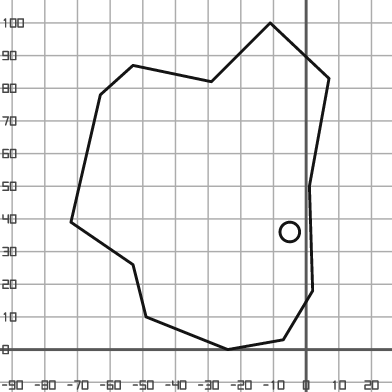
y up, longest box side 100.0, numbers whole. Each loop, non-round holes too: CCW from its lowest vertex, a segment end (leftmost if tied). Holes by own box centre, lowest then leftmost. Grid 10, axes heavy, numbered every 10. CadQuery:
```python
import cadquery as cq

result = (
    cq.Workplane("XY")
    .moveTo(-24.0, 0.0)
    .lineTo(-7.0, 3.0)
    .lineTo(2.0, 18.0)
    .lineTo(1.0, 50.0)
    .lineTo(7.0, 83.0)
    .lineTo(-11.0, 100.0)
    .lineTo(-29.0, 82.0)
    .lineTo(-53.0, 87.0)
    .lineTo(-63.0, 78.0)
    .lineTo(-72.0, 39.0)
    .lineTo(-53.0, 26.0)
    .lineTo(-49.0, 10.0)
    .close()
    .moveTo(-5.0, 36.0)
    .circle(3.0)
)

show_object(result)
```